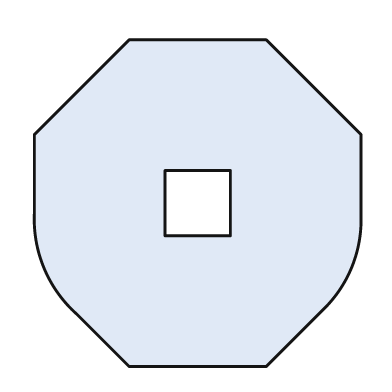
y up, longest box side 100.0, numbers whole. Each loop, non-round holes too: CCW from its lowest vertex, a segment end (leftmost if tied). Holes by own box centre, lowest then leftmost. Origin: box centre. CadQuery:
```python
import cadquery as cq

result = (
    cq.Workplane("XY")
    .moveTo(-21.0, -50.0)
    .lineTo(21.0, -50.0)
    .lineTo(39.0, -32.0)
    .threePointArc((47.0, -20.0), (50.0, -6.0))
    .lineTo(50.0, 21.0)
    .lineTo(21.0, 50.0)
    .lineTo(-21.0, 50.0)
    .lineTo(-50.0, 21.0)
    .lineTo(-50.0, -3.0)
    .threePointArc((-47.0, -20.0), (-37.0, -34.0))
    .close()
    .moveTo(-10.0, -10.0)
    .lineTo(10.0, -10.0)
    .lineTo(10.0, 10.0)
    .lineTo(-10.0, 10.0)
    .close()
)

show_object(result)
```